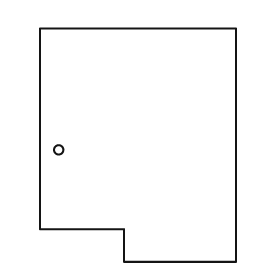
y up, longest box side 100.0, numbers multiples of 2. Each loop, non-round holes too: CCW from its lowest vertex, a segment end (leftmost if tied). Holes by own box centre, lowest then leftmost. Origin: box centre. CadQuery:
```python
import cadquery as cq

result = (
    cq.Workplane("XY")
    .moveTo(-6.0, -50.0)
    .lineTo(42.0, -50.0)
    .lineTo(42.0, 50.0)
    .lineTo(-42.0, 50.0)
    .lineTo(-42.0, -36.0)
    .lineTo(-6.0, -36.0)
    .close()
    .moveTo(-34.0, -2.0)
    .circle(2.0)
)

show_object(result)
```